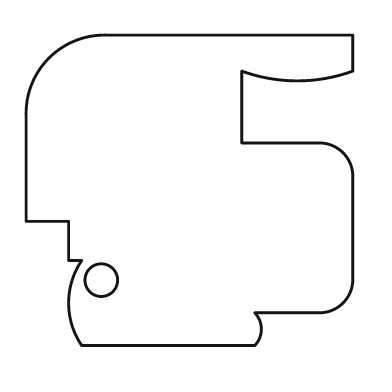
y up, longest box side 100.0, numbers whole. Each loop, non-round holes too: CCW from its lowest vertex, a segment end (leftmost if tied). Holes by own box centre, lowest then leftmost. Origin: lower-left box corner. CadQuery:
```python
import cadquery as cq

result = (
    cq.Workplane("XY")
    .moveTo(17.0, 0.0)
    .lineTo(70.0, 0.0)
    .threePointArc((72.0, 5.0), (70.0, 10.0))
    .lineTo(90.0, 10.0)
    .threePointArc((97.0, 13.0), (100.0, 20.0))
    .lineTo(100.0, 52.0)
    .threePointArc((97.0, 59.0), (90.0, 62.0))
    .lineTo(66.0, 62.0)
    .lineTo(66.0, 84.0)
    .threePointArc((83.0, 81.0), (100.0, 84.0))
    .lineTo(100.0, 95.0)
    .lineTo(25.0, 95.0)
    .threePointArc((7.0, 88.0), (0.0, 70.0))
    .lineTo(0.0, 38.0)
    .lineTo(13.0, 38.0)
    .lineTo(13.0, 26.0)
    .lineTo(17.0, 26.0)
    .threePointArc((13.0, 13.0), (17.0, 0.0))
    .close()
    .moveTo(23.0, 20.0)
    .circle(5.0)
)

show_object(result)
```